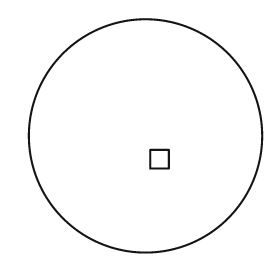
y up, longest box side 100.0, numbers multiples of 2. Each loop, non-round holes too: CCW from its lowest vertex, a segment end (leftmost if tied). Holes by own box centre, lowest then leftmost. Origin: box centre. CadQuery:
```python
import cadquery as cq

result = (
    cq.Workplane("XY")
    .moveTo(0.0, 0.0)
    .circle(50.0)
    .moveTo(2.0, -14.0)
    .lineTo(10.0, -14.0)
    .lineTo(10.0, -6.0)
    .lineTo(2.0, -6.0)
    .close()
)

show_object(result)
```